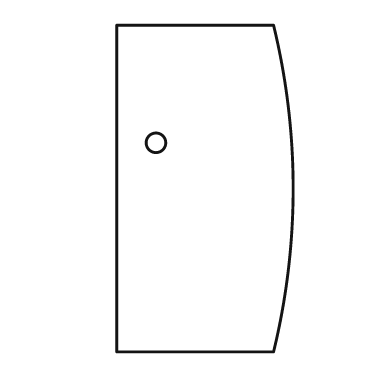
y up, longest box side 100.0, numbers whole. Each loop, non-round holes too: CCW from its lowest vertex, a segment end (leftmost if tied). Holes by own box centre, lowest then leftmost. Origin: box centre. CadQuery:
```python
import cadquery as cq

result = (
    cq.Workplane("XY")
    .moveTo(-27.0, -50.0)
    .lineTo(21.0, -50.0)
    .threePointArc((27.0, 0.0), (21.0, 50.0))
    .lineTo(-27.0, 50.0)
    .close()
    .moveTo(-15.0, 14.0)
    .circle(3.0)
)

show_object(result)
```